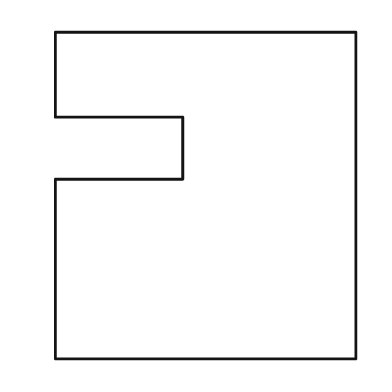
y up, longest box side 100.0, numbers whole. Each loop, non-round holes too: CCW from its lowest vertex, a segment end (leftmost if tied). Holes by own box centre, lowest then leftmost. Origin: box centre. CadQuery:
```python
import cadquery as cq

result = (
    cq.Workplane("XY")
    .moveTo(-46.0, -50.0)
    .lineTo(46.0, -50.0)
    .lineTo(46.0, 50.0)
    .lineTo(-46.0, 50.0)
    .lineTo(-46.0, 24.0)
    .lineTo(-7.0, 24.0)
    .lineTo(-7.0, 5.0)
    .lineTo(-46.0, 5.0)
    .close()
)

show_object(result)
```